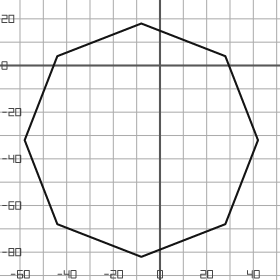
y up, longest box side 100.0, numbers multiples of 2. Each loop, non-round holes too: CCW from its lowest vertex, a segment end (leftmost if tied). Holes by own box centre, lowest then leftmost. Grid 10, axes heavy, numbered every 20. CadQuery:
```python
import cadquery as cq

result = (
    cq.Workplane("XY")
    .moveTo(-8.0, -82.0)
    .lineTo(28.0, -68.0)
    .lineTo(42.0, -32.0)
    .lineTo(28.0, 4.0)
    .lineTo(-8.0, 18.0)
    .lineTo(-44.0, 4.0)
    .lineTo(-58.0, -32.0)
    .lineTo(-44.0, -68.0)
    .close()
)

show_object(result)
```